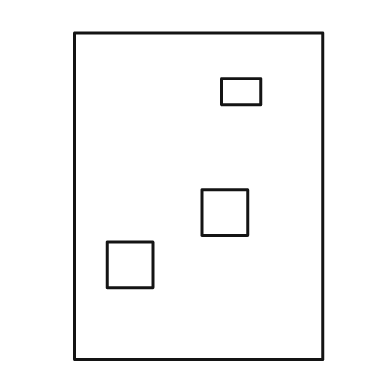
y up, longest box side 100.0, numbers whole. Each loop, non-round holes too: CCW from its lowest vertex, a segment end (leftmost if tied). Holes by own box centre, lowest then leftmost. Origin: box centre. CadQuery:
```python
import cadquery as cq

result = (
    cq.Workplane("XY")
    .moveTo(-38.0, -50.0)
    .lineTo(38.0, -50.0)
    .lineTo(38.0, 50.0)
    .lineTo(-38.0, 50.0)
    .close()
    .moveTo(-28.0, -28.0)
    .lineTo(-14.0, -28.0)
    .lineTo(-14.0, -14.0)
    .lineTo(-28.0, -14.0)
    .close()
    .moveTo(1.0, -12.0)
    .lineTo(15.0, -12.0)
    .lineTo(15.0, 2.0)
    .lineTo(1.0, 2.0)
    .close()
    .moveTo(7.0, 28.0)
    .lineTo(19.0, 28.0)
    .lineTo(19.0, 36.0)
    .lineTo(7.0, 36.0)
    .close()
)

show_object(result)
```